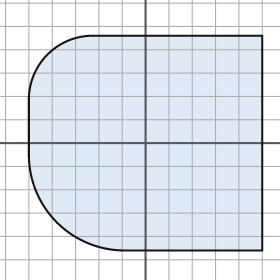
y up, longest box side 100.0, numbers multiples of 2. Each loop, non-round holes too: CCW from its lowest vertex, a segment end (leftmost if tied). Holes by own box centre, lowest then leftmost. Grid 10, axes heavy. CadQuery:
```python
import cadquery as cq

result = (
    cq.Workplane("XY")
    .moveTo(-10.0, -46.0)
    .lineTo(50.0, -46.0)
    .lineTo(50.0, 46.0)
    .lineTo(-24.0, 46.0)
    .threePointArc((-42.0, 38.0), (-50.0, 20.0))
    .lineTo(-50.0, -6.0)
    .threePointArc((-38.0, -34.0), (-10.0, -46.0))
    .close()
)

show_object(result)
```